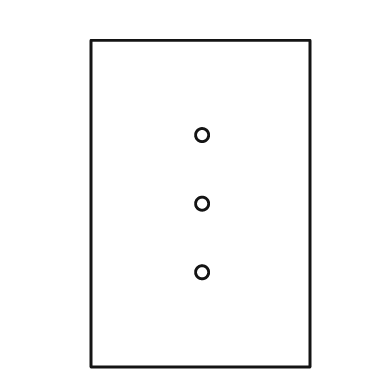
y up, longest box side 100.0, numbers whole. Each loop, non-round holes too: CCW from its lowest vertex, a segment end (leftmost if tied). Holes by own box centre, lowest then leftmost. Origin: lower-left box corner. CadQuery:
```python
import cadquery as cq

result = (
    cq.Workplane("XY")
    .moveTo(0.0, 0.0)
    .lineTo(67.0, 0.0)
    .lineTo(67.0, 100.0)
    .lineTo(0.0, 100.0)
    .close()
    .moveTo(34.0, 29.0)
    .circle(2.0)
    .moveTo(34.0, 50.0)
    .circle(2.0)
    .moveTo(34.0, 71.0)
    .circle(2.0)
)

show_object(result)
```